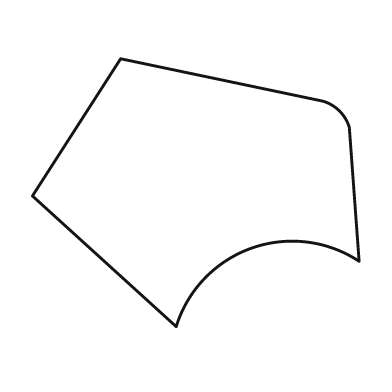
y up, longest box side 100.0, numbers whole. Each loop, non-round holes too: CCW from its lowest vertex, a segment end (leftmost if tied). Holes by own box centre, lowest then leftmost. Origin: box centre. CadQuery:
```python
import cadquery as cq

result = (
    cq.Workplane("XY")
    .moveTo(-6.0, -41.0)
    .threePointArc((17.0, -17.0), (50.0, -21.0))
    .lineTo(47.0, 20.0)
    .threePointArc((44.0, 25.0), (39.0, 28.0))
    .lineTo(-23.0, 41.0)
    .lineTo(-50.0, -1.0)
    .close()
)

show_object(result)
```